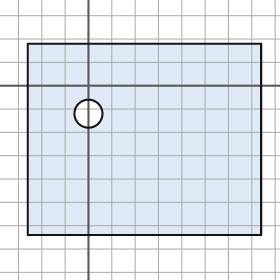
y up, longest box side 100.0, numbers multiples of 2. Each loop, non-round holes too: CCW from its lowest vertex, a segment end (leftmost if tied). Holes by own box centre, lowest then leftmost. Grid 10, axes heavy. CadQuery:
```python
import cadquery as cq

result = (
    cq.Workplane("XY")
    .moveTo(-26.0, -64.0)
    .lineTo(74.0, -64.0)
    .lineTo(74.0, 18.0)
    .lineTo(-26.0, 18.0)
    .close()
    .moveTo(0.0, -12.0)
    .circle(6.0)
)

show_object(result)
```